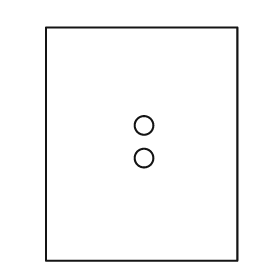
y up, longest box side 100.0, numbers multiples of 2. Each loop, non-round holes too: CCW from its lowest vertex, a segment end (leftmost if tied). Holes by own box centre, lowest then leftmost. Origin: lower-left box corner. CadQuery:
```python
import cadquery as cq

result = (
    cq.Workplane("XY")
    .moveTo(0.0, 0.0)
    .lineTo(82.0, 0.0)
    .lineTo(82.0, 100.0)
    .lineTo(0.0, 100.0)
    .close()
    .moveTo(42.0, 44.0)
    .circle(4.0)
    .moveTo(42.0, 58.0)
    .circle(4.0)
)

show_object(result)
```